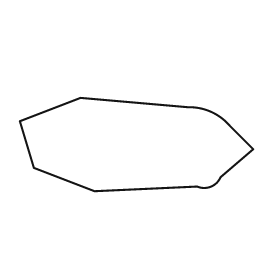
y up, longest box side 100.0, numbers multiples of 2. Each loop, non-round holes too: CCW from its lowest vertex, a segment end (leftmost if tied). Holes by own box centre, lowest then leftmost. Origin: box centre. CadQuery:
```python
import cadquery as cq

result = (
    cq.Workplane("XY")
    .moveTo(-18.0, -20.0)
    .lineTo(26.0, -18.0)
    .threePointArc((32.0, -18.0), (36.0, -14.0))
    .lineTo(50.0, -2.0)
    .lineTo(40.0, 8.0)
    .threePointArc((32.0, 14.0), (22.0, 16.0))
    .lineTo(-24.0, 20.0)
    .lineTo(-50.0, 10.0)
    .lineTo(-44.0, -10.0)
    .close()
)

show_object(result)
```